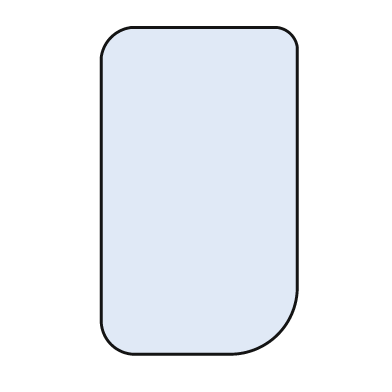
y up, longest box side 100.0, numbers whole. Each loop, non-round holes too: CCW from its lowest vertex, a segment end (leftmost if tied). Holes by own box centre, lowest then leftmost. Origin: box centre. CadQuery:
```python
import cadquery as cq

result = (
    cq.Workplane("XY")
    .moveTo(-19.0, -50.0)
    .lineTo(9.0, -50.0)
    .threePointArc((24.0, -44.0), (30.0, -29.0))
    .lineTo(30.0, 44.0)
    .threePointArc((28.0, 48.0), (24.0, 50.0))
    .lineTo(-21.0, 50.0)
    .threePointArc((-27.0, 47.0), (-30.0, 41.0))
    .lineTo(-30.0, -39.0)
    .threePointArc((-27.0, -47.0), (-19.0, -50.0))
    .close()
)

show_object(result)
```